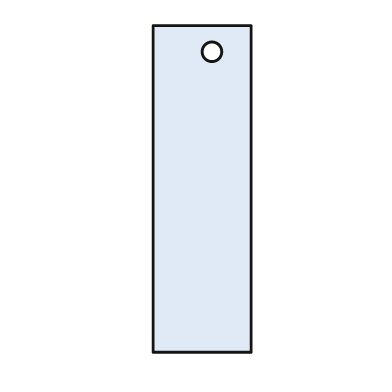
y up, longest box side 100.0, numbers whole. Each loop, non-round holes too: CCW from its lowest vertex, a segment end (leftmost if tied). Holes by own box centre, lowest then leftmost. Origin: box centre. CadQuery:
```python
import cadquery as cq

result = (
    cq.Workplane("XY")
    .moveTo(-15.0, -50.0)
    .lineTo(15.0, -50.0)
    .lineTo(15.0, 50.0)
    .lineTo(-15.0, 50.0)
    .close()
    .moveTo(3.0, 42.0)
    .circle(3.0)
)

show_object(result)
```